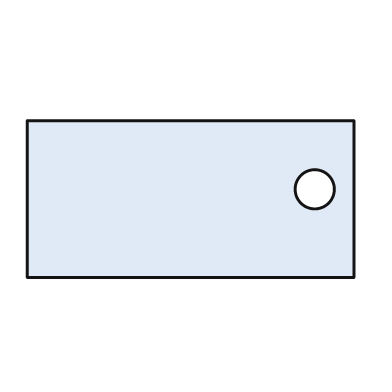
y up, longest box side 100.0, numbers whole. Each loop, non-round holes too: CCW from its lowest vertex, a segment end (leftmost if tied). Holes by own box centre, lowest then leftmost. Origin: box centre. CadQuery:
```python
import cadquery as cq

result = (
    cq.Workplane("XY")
    .moveTo(-50.0, -24.0)
    .lineTo(50.0, -24.0)
    .lineTo(50.0, 24.0)
    .lineTo(-50.0, 24.0)
    .close()
    .moveTo(38.0, 3.0)
    .circle(6.0)
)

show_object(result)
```